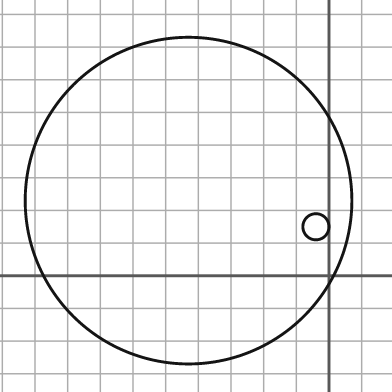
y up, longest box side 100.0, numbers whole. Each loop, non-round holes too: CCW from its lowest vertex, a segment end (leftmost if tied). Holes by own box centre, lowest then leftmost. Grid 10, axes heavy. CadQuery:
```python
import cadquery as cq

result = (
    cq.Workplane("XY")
    .moveTo(-43.0, 23.0)
    .circle(50.0)
    .moveTo(-4.0, 15.0)
    .circle(4.0)
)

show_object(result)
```